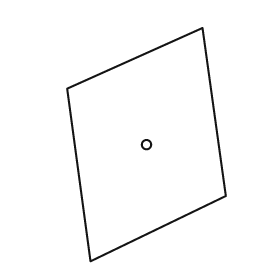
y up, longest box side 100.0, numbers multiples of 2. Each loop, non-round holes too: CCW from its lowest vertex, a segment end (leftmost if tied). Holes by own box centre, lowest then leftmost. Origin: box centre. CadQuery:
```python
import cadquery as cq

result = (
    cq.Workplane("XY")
    .moveTo(-24.0, -50.0)
    .lineTo(34.0, -22.0)
    .lineTo(24.0, 50.0)
    .lineTo(-34.0, 24.0)
    .close()
    .moveTo(0.0, 0.0)
    .circle(2.0)
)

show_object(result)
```